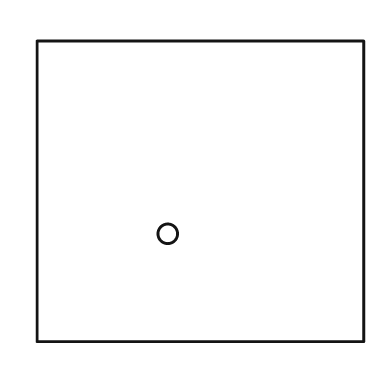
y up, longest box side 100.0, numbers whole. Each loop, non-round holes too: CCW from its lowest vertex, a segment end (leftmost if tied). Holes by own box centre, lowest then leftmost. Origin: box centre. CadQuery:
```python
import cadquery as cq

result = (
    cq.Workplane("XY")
    .moveTo(-50.0, -46.0)
    .lineTo(50.0, -46.0)
    .lineTo(50.0, 46.0)
    .lineTo(-50.0, 46.0)
    .close()
    .moveTo(-10.0, -13.0)
    .circle(3.0)
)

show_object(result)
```